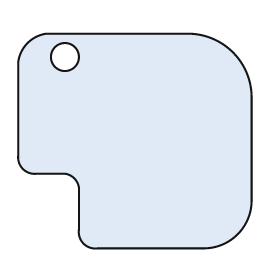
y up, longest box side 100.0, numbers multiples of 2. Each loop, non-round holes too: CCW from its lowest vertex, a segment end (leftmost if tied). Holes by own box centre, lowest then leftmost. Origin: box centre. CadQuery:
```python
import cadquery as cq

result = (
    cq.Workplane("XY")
    .moveTo(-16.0, -46.0)
    .lineTo(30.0, -46.0)
    .threePointArc((44.0, -40.0), (50.0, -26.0))
    .lineTo(50.0, 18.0)
    .threePointArc((42.0, 38.0), (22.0, 46.0))
    .lineTo(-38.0, 46.0)
    .threePointArc((-46.0, 42.0), (-50.0, 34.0))
    .lineTo(-50.0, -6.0)
    .threePointArc((-48.0, -12.0), (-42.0, -14.0))
    .lineTo(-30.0, -14.0)
    .threePointArc((-26.0, -16.0), (-24.0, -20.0))
    .lineTo(-24.0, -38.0)
    .threePointArc((-22.0, -44.0), (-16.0, -46.0))
    .close()
    .moveTo(-30.0, 36.0)
    .circle(6.0)
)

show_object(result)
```